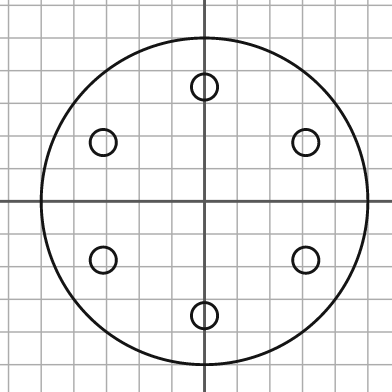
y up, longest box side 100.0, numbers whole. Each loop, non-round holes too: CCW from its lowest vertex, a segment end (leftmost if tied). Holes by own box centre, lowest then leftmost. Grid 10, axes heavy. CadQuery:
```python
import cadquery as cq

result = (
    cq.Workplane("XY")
    .moveTo(0.0, 0.0)
    .circle(50.0)
    .moveTo(0.0, -35.0)
    .circle(4.0)
    .moveTo(-31.0, -18.0)
    .circle(4.0)
    .moveTo(31.0, -18.0)
    .circle(4.0)
    .moveTo(-31.0, 18.0)
    .circle(4.0)
    .moveTo(31.0, 18.0)
    .circle(4.0)
    .moveTo(0.0, 35.0)
    .circle(4.0)
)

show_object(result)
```